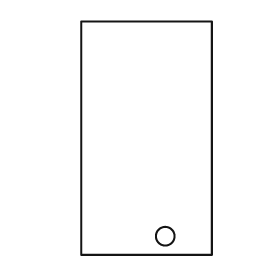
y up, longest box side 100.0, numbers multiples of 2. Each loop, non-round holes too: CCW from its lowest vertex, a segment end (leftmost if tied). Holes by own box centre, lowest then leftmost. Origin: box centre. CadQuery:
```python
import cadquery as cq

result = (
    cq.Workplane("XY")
    .moveTo(-28.0, -50.0)
    .lineTo(28.0, -50.0)
    .lineTo(28.0, 50.0)
    .lineTo(-28.0, 50.0)
    .close()
    .moveTo(8.0, -42.0)
    .circle(4.0)
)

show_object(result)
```